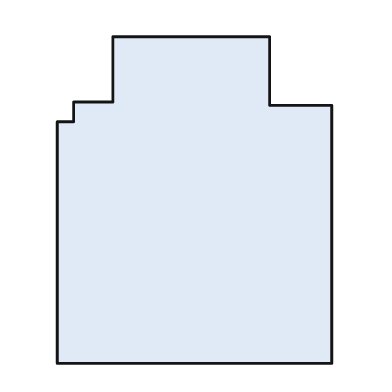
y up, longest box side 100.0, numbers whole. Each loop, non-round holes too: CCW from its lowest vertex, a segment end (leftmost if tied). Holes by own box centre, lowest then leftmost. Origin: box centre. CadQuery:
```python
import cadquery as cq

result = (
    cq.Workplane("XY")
    .moveTo(-42.0, -50.0)
    .lineTo(42.0, -50.0)
    .lineTo(42.0, 29.0)
    .lineTo(23.0, 29.0)
    .lineTo(23.0, 50.0)
    .lineTo(-25.0, 50.0)
    .lineTo(-25.0, 30.0)
    .lineTo(-37.0, 30.0)
    .lineTo(-37.0, 24.0)
    .lineTo(-42.0, 24.0)
    .close()
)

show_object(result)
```